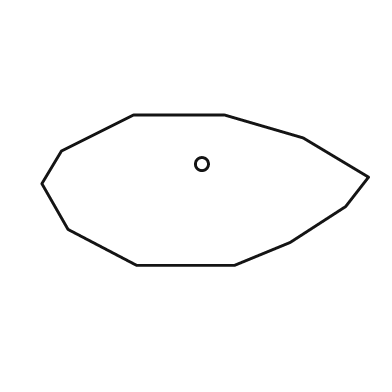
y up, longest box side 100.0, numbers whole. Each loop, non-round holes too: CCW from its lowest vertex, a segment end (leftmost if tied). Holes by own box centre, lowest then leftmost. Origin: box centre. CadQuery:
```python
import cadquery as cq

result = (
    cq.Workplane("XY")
    .moveTo(-21.0, -23.0)
    .lineTo(9.0, -23.0)
    .lineTo(26.0, -16.0)
    .lineTo(43.0, -5.0)
    .lineTo(50.0, 4.0)
    .lineTo(30.0, 16.0)
    .lineTo(6.0, 23.0)
    .lineTo(-22.0, 23.0)
    .lineTo(-44.0, 12.0)
    .lineTo(-50.0, 2.0)
    .lineTo(-42.0, -12.0)
    .close()
    .moveTo(-1.0, 8.0)
    .circle(2.0)
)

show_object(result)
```